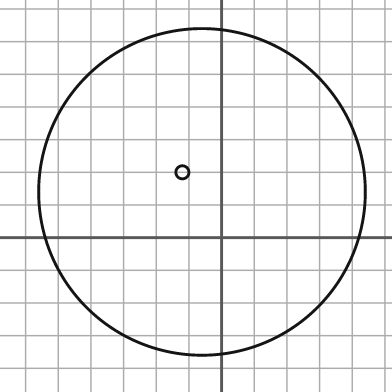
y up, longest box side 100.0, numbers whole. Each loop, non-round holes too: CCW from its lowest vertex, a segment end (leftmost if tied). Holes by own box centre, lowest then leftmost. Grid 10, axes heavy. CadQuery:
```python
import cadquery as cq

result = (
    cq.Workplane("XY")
    .moveTo(-6.0, 14.0)
    .circle(50.0)
    .moveTo(-12.0, 20.0)
    .circle(2.0)
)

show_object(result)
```